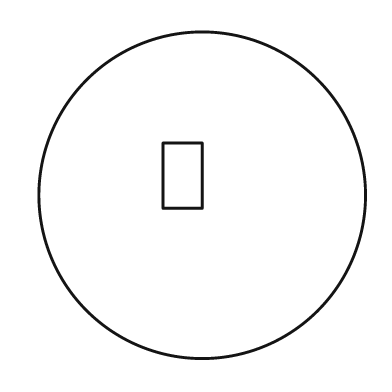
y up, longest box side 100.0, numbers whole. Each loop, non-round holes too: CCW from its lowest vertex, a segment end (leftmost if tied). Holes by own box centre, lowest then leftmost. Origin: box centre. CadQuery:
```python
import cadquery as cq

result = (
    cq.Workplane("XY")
    .moveTo(0.0, 0.0)
    .circle(50.0)
    .moveTo(-12.0, -4.0)
    .lineTo(0.0, -4.0)
    .lineTo(0.0, 16.0)
    .lineTo(-12.0, 16.0)
    .close()
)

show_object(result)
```